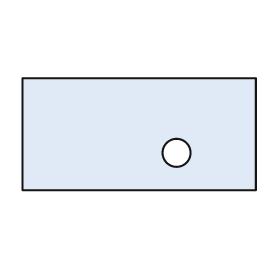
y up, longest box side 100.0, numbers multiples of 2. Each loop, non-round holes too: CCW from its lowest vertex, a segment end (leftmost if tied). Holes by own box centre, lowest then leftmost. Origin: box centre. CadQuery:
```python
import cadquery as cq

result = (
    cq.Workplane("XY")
    .moveTo(-50.0, -24.0)
    .lineTo(50.0, -24.0)
    .lineTo(50.0, 24.0)
    .lineTo(-50.0, 24.0)
    .close()
    .moveTo(16.0, -8.0)
    .circle(6.0)
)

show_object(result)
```